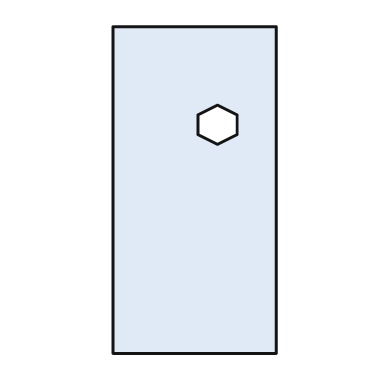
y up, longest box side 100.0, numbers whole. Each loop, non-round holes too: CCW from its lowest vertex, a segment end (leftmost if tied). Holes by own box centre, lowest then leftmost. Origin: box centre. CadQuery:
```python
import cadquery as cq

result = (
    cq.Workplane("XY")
    .moveTo(-25.0, -50.0)
    .lineTo(25.0, -50.0)
    .lineTo(25.0, 50.0)
    .lineTo(-25.0, 50.0)
    .close()
    .moveTo(7.0, 14.0)
    .lineTo(13.0, 17.0)
    .lineTo(13.0, 23.0)
    .lineTo(7.0, 26.0)
    .lineTo(1.0, 23.0)
    .lineTo(1.0, 17.0)
    .close()
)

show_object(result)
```